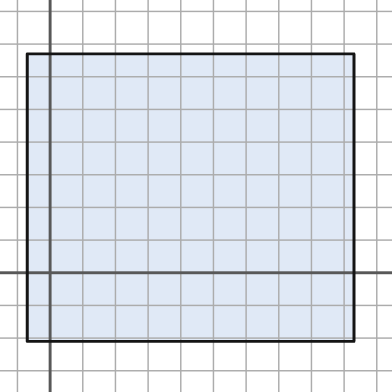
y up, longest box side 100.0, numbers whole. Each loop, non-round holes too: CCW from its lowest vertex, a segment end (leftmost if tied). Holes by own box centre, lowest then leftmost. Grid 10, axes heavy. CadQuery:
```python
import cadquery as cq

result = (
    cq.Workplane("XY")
    .moveTo(-7.0, -21.0)
    .lineTo(93.0, -21.0)
    .lineTo(93.0, 67.0)
    .lineTo(-7.0, 67.0)
    .close()
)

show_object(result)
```